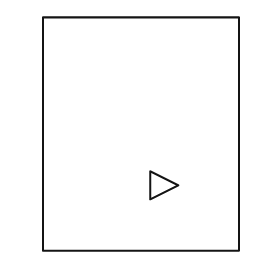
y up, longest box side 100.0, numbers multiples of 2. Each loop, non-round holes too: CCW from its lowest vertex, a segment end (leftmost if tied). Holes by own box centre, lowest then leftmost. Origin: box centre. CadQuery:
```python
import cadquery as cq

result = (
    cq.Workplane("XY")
    .moveTo(-42.0, -50.0)
    .lineTo(42.0, -50.0)
    .lineTo(42.0, 50.0)
    .lineTo(-42.0, 50.0)
    .close()
    .moveTo(4.0, -28.0)
    .lineTo(16.0, -22.0)
    .lineTo(4.0, -16.0)
    .close()
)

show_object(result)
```